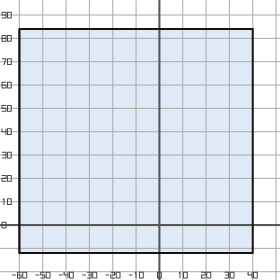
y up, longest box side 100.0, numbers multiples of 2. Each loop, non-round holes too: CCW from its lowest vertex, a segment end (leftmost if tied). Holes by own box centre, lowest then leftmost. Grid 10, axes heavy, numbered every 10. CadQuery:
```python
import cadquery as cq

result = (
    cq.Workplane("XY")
    .moveTo(-60.0, -12.0)
    .lineTo(40.0, -12.0)
    .lineTo(40.0, 84.0)
    .lineTo(-60.0, 84.0)
    .close()
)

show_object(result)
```